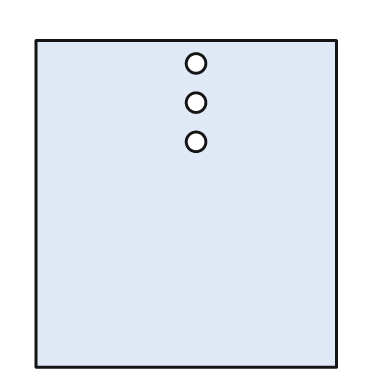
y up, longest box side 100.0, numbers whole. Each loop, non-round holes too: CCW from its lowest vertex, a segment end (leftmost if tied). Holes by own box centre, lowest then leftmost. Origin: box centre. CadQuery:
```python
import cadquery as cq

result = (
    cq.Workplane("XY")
    .moveTo(-46.0, -50.0)
    .lineTo(46.0, -50.0)
    .lineTo(46.0, 50.0)
    .lineTo(-46.0, 50.0)
    .close()
    .moveTo(3.0, 19.0)
    .circle(3.0)
    .moveTo(3.0, 31.0)
    .circle(3.0)
    .moveTo(3.0, 43.0)
    .circle(3.0)
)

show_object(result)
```